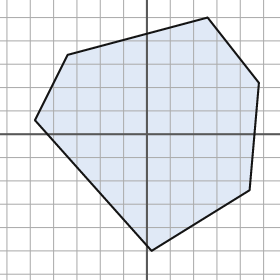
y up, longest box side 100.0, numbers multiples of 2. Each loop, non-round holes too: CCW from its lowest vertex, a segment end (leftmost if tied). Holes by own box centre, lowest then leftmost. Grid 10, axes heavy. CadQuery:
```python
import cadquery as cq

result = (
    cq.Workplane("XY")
    .moveTo(2.0, -50.0)
    .lineTo(44.0, -24.0)
    .lineTo(48.0, 22.0)
    .lineTo(26.0, 50.0)
    .lineTo(-34.0, 34.0)
    .lineTo(-48.0, 6.0)
    .close()
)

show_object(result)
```